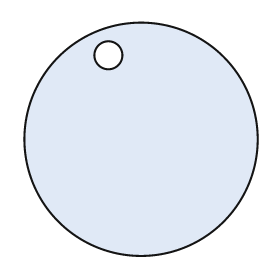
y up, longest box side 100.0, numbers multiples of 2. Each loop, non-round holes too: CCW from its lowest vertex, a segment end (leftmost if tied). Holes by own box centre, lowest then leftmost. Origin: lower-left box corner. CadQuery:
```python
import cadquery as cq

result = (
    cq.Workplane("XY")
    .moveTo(50.0, 50.0)
    .circle(50.0)
    .moveTo(36.0, 86.0)
    .circle(6.0)
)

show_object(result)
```